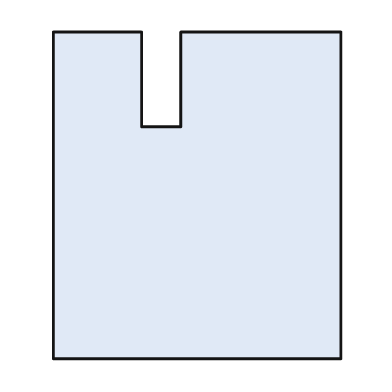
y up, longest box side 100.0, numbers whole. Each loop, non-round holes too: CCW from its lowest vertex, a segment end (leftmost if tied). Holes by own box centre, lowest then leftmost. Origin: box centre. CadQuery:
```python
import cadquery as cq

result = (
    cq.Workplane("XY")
    .moveTo(-44.0, -50.0)
    .lineTo(44.0, -50.0)
    .lineTo(44.0, 50.0)
    .lineTo(-5.0, 50.0)
    .lineTo(-5.0, 21.0)
    .lineTo(-17.0, 21.0)
    .lineTo(-17.0, 50.0)
    .lineTo(-44.0, 50.0)
    .close()
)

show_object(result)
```